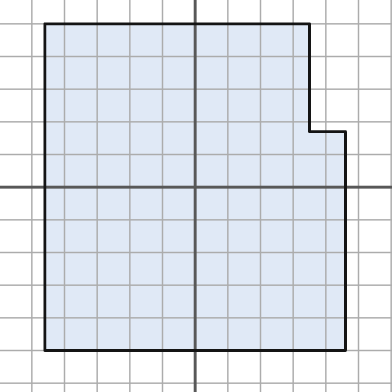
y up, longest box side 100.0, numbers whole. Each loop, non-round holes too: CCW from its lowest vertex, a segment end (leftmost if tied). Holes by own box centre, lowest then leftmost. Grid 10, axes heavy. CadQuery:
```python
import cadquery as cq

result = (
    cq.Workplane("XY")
    .moveTo(-46.0, -50.0)
    .lineTo(46.0, -50.0)
    .lineTo(46.0, 17.0)
    .lineTo(35.0, 17.0)
    .lineTo(35.0, 50.0)
    .lineTo(-46.0, 50.0)
    .close()
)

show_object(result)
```